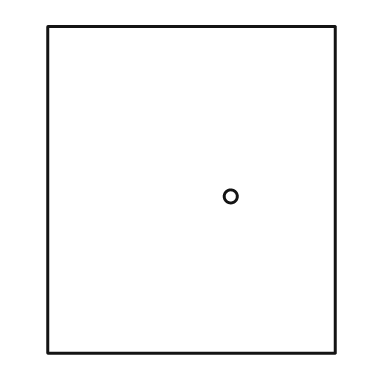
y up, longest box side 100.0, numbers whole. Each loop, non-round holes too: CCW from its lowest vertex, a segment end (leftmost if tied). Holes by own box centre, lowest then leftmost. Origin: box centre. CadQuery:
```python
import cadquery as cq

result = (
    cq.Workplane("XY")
    .moveTo(-44.0, -50.0)
    .lineTo(44.0, -50.0)
    .lineTo(44.0, 50.0)
    .lineTo(-44.0, 50.0)
    .close()
    .moveTo(12.0, -2.0)
    .circle(2.0)
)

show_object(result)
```